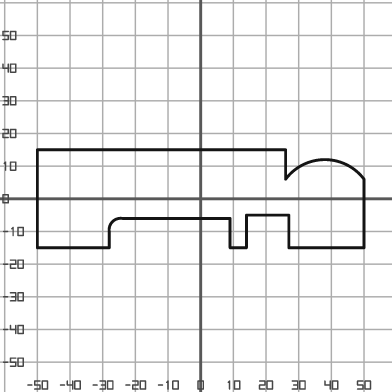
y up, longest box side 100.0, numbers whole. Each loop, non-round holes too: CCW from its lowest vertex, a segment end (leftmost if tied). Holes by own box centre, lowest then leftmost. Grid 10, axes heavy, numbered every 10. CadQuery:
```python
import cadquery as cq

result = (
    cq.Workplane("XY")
    .moveTo(-50.0, -15.0)
    .lineTo(-28.0, -15.0)
    .lineTo(-28.0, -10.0)
    .threePointArc((-27.0, -7.0), (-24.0, -6.0))
    .lineTo(9.0, -6.0)
    .lineTo(9.0, -15.0)
    .lineTo(14.0, -15.0)
    .lineTo(14.0, -5.0)
    .lineTo(27.0, -5.0)
    .lineTo(27.0, -15.0)
    .lineTo(50.0, -15.0)
    .lineTo(50.0, 6.0)
    .threePointArc((38.0, 12.0), (26.0, 6.0))
    .lineTo(26.0, 15.0)
    .lineTo(-50.0, 15.0)
    .close()
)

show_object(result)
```